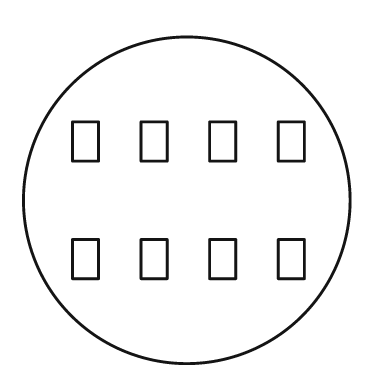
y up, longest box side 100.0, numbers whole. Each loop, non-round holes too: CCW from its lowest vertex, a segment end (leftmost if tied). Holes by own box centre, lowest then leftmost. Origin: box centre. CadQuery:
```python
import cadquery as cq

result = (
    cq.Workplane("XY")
    .moveTo(0.0, 0.0)
    .circle(50.0)
    .moveTo(-35.0, -24.0)
    .lineTo(-27.0, -24.0)
    .lineTo(-27.0, -12.0)
    .lineTo(-35.0, -12.0)
    .close()
    .moveTo(-14.0, -24.0)
    .lineTo(-6.0, -24.0)
    .lineTo(-6.0, -12.0)
    .lineTo(-14.0, -12.0)
    .close()
    .moveTo(7.0, -24.0)
    .lineTo(15.0, -24.0)
    .lineTo(15.0, -12.0)
    .lineTo(7.0, -12.0)
    .close()
    .moveTo(28.0, -24.0)
    .lineTo(36.0, -24.0)
    .lineTo(36.0, -12.0)
    .lineTo(28.0, -12.0)
    .close()
    .moveTo(-35.0, 12.0)
    .lineTo(-27.0, 12.0)
    .lineTo(-27.0, 24.0)
    .lineTo(-35.0, 24.0)
    .close()
    .moveTo(-14.0, 12.0)
    .lineTo(-6.0, 12.0)
    .lineTo(-6.0, 24.0)
    .lineTo(-14.0, 24.0)
    .close()
    .moveTo(7.0, 12.0)
    .lineTo(15.0, 12.0)
    .lineTo(15.0, 24.0)
    .lineTo(7.0, 24.0)
    .close()
    .moveTo(28.0, 12.0)
    .lineTo(36.0, 12.0)
    .lineTo(36.0, 24.0)
    .lineTo(28.0, 24.0)
    .close()
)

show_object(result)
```